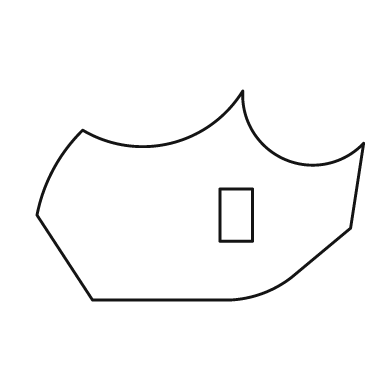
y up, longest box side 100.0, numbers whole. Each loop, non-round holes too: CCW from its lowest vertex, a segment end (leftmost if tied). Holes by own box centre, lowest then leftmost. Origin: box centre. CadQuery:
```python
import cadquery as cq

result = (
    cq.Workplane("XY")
    .moveTo(-33.0, -32.0)
    .lineTo(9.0, -32.0)
    .threePointArc((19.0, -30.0), (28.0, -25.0))
    .lineTo(46.0, -10.0)
    .lineTo(50.0, 16.0)
    .threePointArc((26.0, 11.0), (13.0, 32.0))
    .threePointArc((-9.0, 16.0), (-36.0, 20.0))
    .threePointArc((-45.0, 8.0), (-50.0, -6.0))
    .close()
    .moveTo(6.0, -14.0)
    .lineTo(16.0, -14.0)
    .lineTo(16.0, 2.0)
    .lineTo(6.0, 2.0)
    .close()
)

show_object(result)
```